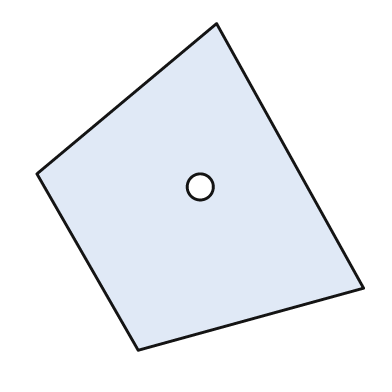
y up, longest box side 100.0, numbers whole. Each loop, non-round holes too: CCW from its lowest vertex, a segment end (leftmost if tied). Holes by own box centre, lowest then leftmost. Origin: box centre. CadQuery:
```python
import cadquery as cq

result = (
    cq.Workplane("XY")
    .moveTo(-19.0, -50.0)
    .lineTo(50.0, -31.0)
    .lineTo(5.0, 50.0)
    .lineTo(-50.0, 4.0)
    .close()
    .moveTo(0.0, 0.0)
    .circle(4.0)
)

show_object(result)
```